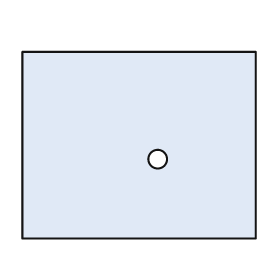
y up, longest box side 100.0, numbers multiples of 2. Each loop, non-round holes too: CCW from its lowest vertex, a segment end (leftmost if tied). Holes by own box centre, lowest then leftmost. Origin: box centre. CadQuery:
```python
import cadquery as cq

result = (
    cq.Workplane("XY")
    .moveTo(-50.0, -40.0)
    .lineTo(50.0, -40.0)
    .lineTo(50.0, 40.0)
    .lineTo(-50.0, 40.0)
    .close()
    .moveTo(8.0, -6.0)
    .circle(4.0)
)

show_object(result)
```